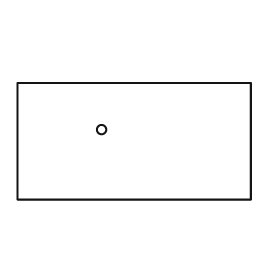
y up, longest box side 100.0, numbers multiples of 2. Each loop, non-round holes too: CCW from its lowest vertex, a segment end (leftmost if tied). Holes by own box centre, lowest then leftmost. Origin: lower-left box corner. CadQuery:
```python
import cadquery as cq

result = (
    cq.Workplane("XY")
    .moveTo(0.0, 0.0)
    .lineTo(100.0, 0.0)
    .lineTo(100.0, 50.0)
    .lineTo(0.0, 50.0)
    .close()
    .moveTo(36.0, 30.0)
    .circle(2.0)
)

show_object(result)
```